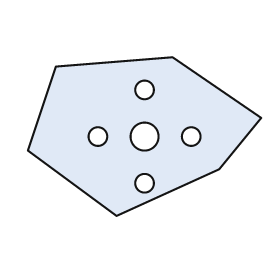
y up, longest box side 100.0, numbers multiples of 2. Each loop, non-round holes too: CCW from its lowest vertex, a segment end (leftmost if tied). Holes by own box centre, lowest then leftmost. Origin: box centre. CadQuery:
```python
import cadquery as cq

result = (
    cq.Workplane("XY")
    .moveTo(-12.0, -34.0)
    .lineTo(32.0, -14.0)
    .lineTo(50.0, 8.0)
    .lineTo(12.0, 34.0)
    .lineTo(-38.0, 30.0)
    .lineTo(-50.0, -6.0)
    .close()
    .moveTo(0.0, -20.0)
    .circle(4.0)
    .moveTo(-20.0, 0.0)
    .circle(4.0)
    .moveTo(0.0, 0.0)
    .circle(6.0)
    .moveTo(20.0, 0.0)
    .circle(4.0)
    .moveTo(0.0, 20.0)
    .circle(4.0)
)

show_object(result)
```